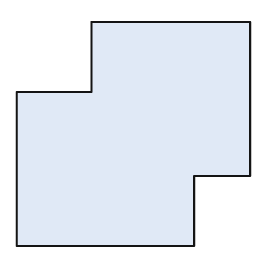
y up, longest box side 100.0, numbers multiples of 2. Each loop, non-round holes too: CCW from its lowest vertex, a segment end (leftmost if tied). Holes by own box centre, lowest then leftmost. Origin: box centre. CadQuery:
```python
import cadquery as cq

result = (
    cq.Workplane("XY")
    .moveTo(-50.0, -48.0)
    .lineTo(26.0, -48.0)
    .lineTo(26.0, -18.0)
    .lineTo(50.0, -18.0)
    .lineTo(50.0, 48.0)
    .lineTo(-18.0, 48.0)
    .lineTo(-18.0, 18.0)
    .lineTo(-50.0, 18.0)
    .close()
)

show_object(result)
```